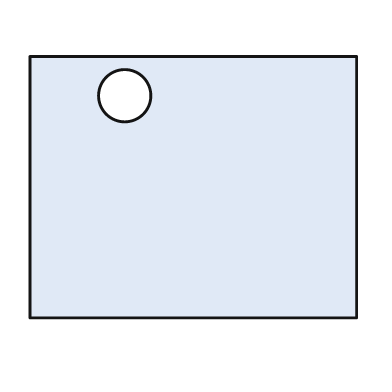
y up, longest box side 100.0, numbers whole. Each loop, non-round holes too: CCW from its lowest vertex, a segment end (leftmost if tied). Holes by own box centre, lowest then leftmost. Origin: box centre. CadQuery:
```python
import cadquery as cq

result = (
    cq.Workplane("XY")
    .moveTo(-50.0, -40.0)
    .lineTo(50.0, -40.0)
    .lineTo(50.0, 40.0)
    .lineTo(-50.0, 40.0)
    .close()
    .moveTo(-21.0, 28.0)
    .circle(8.0)
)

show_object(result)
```